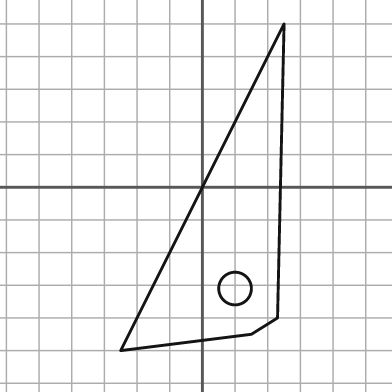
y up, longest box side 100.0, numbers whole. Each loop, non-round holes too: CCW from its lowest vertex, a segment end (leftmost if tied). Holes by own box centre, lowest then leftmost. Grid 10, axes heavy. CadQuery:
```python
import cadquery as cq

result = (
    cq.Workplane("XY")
    .moveTo(-25.0, -50.0)
    .lineTo(15.0, -45.0)
    .lineTo(23.0, -40.0)
    .lineTo(25.0, 50.0)
    .close()
    .moveTo(10.0, -31.0)
    .circle(5.0)
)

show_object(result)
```